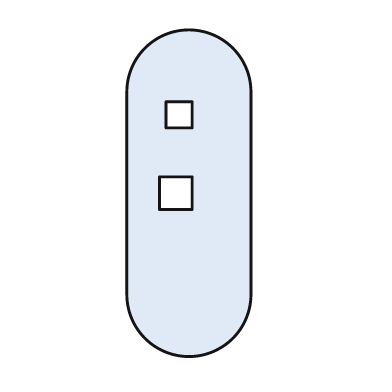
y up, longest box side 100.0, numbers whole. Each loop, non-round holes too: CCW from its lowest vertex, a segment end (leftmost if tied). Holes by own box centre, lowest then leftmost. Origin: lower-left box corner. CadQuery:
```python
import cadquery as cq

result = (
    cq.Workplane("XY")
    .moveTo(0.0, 19.0)
    .threePointArc((19.0, 0.0), (38.0, 19.0))
    .lineTo(38.0, 81.0)
    .threePointArc((19.0, 100.0), (0.0, 81.0))
    .close()
    .moveTo(10.0, 45.0)
    .lineTo(20.0, 45.0)
    .lineTo(20.0, 55.0)
    .lineTo(10.0, 55.0)
    .close()
    .moveTo(12.0, 70.0)
    .lineTo(20.0, 70.0)
    .lineTo(20.0, 78.0)
    .lineTo(12.0, 78.0)
    .close()
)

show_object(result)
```